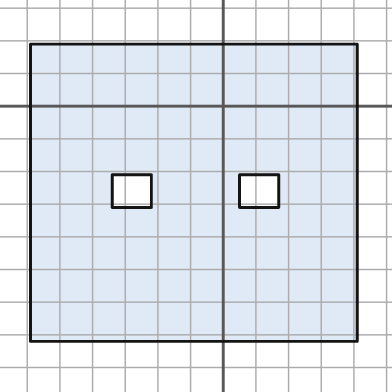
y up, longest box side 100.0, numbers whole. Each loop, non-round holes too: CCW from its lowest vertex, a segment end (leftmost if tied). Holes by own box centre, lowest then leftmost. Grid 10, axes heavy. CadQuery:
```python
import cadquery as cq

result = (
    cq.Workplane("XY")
    .moveTo(-59.0, -72.0)
    .lineTo(41.0, -72.0)
    .lineTo(41.0, 19.0)
    .lineTo(-59.0, 19.0)
    .close()
    .moveTo(-34.0, -31.0)
    .lineTo(-22.0, -31.0)
    .lineTo(-22.0, -21.0)
    .lineTo(-34.0, -21.0)
    .close()
    .moveTo(5.0, -31.0)
    .lineTo(17.0, -31.0)
    .lineTo(17.0, -21.0)
    .lineTo(5.0, -21.0)
    .close()
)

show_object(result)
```